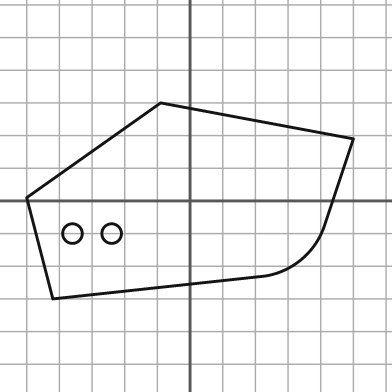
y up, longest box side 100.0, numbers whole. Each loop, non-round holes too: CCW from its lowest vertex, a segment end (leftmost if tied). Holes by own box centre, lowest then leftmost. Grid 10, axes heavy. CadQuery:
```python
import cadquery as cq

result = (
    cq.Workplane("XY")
    .moveTo(-42.0, -30.0)
    .lineTo(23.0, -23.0)
    .threePointArc((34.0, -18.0), (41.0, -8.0))
    .lineTo(50.0, 19.0)
    .lineTo(-9.0, 30.0)
    .lineTo(-50.0, 1.0)
    .close()
    .moveTo(-36.0, -10.0)
    .circle(3.0)
    .moveTo(-24.0, -10.0)
    .circle(3.0)
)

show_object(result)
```